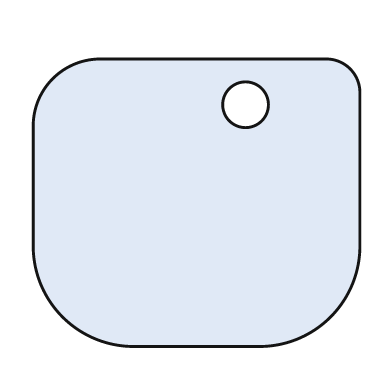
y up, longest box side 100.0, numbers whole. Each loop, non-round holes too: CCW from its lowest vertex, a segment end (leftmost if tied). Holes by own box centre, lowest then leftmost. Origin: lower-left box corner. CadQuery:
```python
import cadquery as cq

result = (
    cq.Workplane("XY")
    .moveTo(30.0, 0.0)
    .lineTo(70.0, 0.0)
    .threePointArc((91.0, 9.0), (100.0, 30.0))
    .lineTo(100.0, 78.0)
    .threePointArc((97.0, 85.0), (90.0, 88.0))
    .lineTo(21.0, 88.0)
    .threePointArc((6.0, 82.0), (0.0, 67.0))
    .lineTo(0.0, 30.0)
    .threePointArc((9.0, 9.0), (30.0, 0.0))
    .close()
    .moveTo(65.0, 74.0)
    .circle(7.0)
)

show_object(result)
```